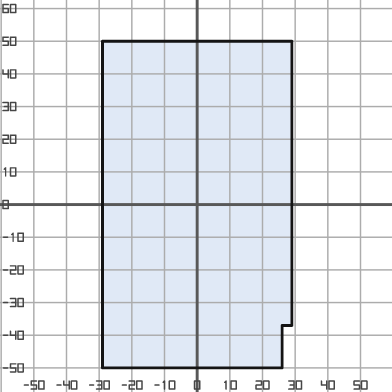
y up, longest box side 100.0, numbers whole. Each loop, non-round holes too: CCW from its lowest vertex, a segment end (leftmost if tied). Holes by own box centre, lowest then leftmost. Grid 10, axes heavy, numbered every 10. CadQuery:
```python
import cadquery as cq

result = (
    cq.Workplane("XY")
    .moveTo(-29.0, -50.0)
    .lineTo(26.0, -50.0)
    .lineTo(26.0, -37.0)
    .lineTo(29.0, -37.0)
    .lineTo(29.0, 50.0)
    .lineTo(-29.0, 50.0)
    .close()
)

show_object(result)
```